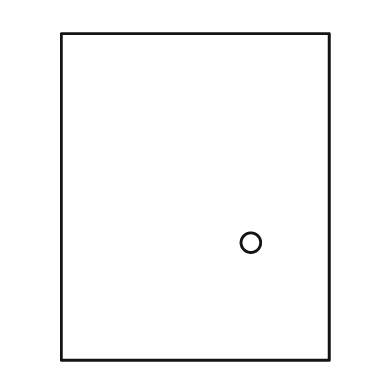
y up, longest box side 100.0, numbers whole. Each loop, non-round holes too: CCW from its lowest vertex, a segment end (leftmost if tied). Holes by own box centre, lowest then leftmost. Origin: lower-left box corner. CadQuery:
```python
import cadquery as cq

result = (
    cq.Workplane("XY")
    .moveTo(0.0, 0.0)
    .lineTo(82.0, 0.0)
    .lineTo(82.0, 100.0)
    .lineTo(0.0, 100.0)
    .close()
    .moveTo(58.0, 36.0)
    .circle(3.0)
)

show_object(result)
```